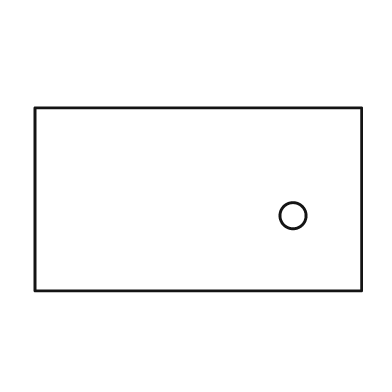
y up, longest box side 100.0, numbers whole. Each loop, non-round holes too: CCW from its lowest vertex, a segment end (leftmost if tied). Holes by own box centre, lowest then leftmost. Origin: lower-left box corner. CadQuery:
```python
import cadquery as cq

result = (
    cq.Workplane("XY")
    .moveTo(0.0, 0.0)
    .lineTo(100.0, 0.0)
    .lineTo(100.0, 56.0)
    .lineTo(0.0, 56.0)
    .close()
    .moveTo(79.0, 23.0)
    .circle(4.0)
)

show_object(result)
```